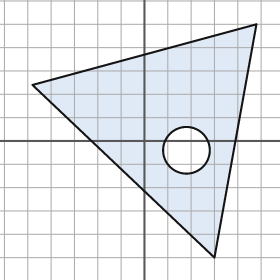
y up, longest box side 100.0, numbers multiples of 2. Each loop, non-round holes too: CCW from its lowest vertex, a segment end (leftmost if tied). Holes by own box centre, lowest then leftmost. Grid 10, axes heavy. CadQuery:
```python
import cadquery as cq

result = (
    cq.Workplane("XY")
    .moveTo(30.0, -50.0)
    .lineTo(48.0, 50.0)
    .lineTo(-48.0, 24.0)
    .close()
    .moveTo(18.0, -4.0)
    .circle(10.0)
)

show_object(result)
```